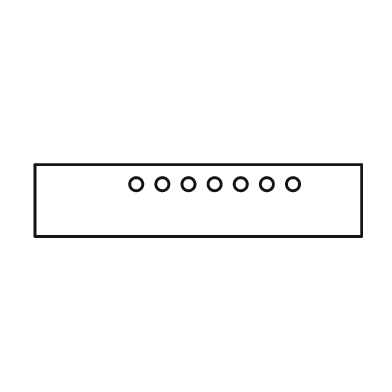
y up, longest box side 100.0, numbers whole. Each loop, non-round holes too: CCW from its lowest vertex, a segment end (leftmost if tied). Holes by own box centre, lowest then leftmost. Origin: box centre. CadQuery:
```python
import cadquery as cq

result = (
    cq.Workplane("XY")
    .moveTo(-50.0, -11.0)
    .lineTo(50.0, -11.0)
    .lineTo(50.0, 11.0)
    .lineTo(-50.0, 11.0)
    .close()
    .moveTo(-19.0, 5.0)
    .circle(2.0)
    .moveTo(-11.0, 5.0)
    .circle(2.0)
    .moveTo(-3.0, 5.0)
    .circle(2.0)
    .moveTo(5.0, 5.0)
    .circle(2.0)
    .moveTo(13.0, 5.0)
    .circle(2.0)
    .moveTo(21.0, 5.0)
    .circle(2.0)
    .moveTo(29.0, 5.0)
    .circle(2.0)
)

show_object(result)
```